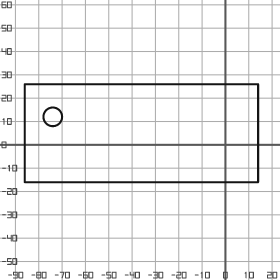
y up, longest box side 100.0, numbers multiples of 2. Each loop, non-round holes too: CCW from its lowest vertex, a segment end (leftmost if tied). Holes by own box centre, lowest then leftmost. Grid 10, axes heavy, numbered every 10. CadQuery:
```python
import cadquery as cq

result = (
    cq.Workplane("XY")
    .moveTo(-86.0, -16.0)
    .lineTo(14.0, -16.0)
    .lineTo(14.0, 26.0)
    .lineTo(-86.0, 26.0)
    .close()
    .moveTo(-74.0, 12.0)
    .circle(4.0)
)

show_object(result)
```